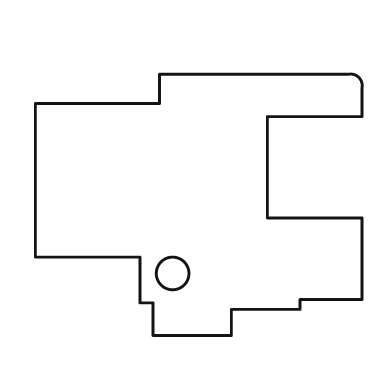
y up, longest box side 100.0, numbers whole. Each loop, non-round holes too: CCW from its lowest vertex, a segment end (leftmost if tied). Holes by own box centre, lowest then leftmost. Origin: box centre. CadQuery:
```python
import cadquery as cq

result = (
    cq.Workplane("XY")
    .moveTo(-14.0, -40.0)
    .lineTo(10.0, -40.0)
    .lineTo(10.0, -32.0)
    .lineTo(31.0, -32.0)
    .lineTo(31.0, -29.0)
    .lineTo(50.0, -29.0)
    .lineTo(50.0, -4.0)
    .lineTo(21.0, -4.0)
    .lineTo(21.0, 27.0)
    .lineTo(50.0, 27.0)
    .lineTo(50.0, 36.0)
    .threePointArc((49.0, 39.0), (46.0, 40.0))
    .lineTo(-12.0, 40.0)
    .lineTo(-12.0, 31.0)
    .lineTo(-50.0, 31.0)
    .lineTo(-50.0, -16.0)
    .lineTo(-18.0, -16.0)
    .lineTo(-18.0, -30.0)
    .lineTo(-14.0, -30.0)
    .close()
    .moveTo(-8.0, -21.0)
    .circle(5.0)
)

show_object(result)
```